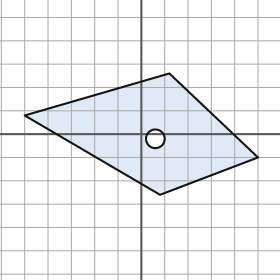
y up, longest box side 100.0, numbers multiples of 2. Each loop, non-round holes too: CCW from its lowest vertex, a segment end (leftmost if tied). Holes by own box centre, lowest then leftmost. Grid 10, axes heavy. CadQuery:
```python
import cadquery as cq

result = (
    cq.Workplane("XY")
    .moveTo(8.0, -26.0)
    .lineTo(50.0, -10.0)
    .lineTo(12.0, 26.0)
    .lineTo(-50.0, 8.0)
    .close()
    .moveTo(6.0, -2.0)
    .circle(4.0)
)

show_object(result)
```